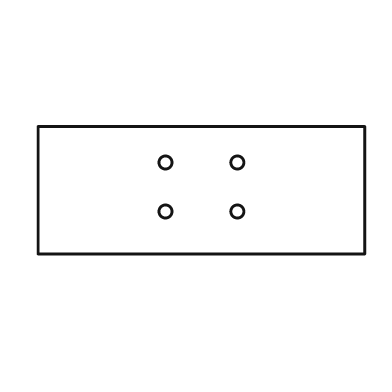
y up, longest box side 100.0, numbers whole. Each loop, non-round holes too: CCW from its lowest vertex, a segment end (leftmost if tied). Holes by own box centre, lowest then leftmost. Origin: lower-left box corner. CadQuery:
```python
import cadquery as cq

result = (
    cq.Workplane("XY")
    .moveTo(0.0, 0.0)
    .lineTo(100.0, 0.0)
    .lineTo(100.0, 39.0)
    .lineTo(0.0, 39.0)
    .close()
    .moveTo(39.0, 13.0)
    .circle(2.0)
    .moveTo(61.0, 13.0)
    .circle(2.0)
    .moveTo(39.0, 28.0)
    .circle(2.0)
    .moveTo(61.0, 28.0)
    .circle(2.0)
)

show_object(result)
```